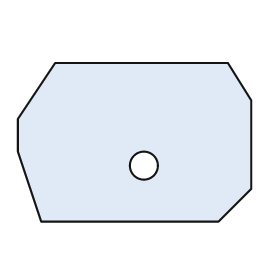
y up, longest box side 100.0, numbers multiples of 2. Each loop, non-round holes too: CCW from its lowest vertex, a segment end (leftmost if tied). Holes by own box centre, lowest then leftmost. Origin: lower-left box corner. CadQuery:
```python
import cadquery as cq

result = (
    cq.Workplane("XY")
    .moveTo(10.0, 0.0)
    .lineTo(86.0, 0.0)
    .lineTo(100.0, 14.0)
    .lineTo(100.0, 52.0)
    .lineTo(90.0, 68.0)
    .lineTo(16.0, 68.0)
    .lineTo(0.0, 44.0)
    .lineTo(0.0, 30.0)
    .close()
    .moveTo(54.0, 24.0)
    .circle(6.0)
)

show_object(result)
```